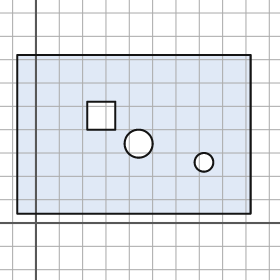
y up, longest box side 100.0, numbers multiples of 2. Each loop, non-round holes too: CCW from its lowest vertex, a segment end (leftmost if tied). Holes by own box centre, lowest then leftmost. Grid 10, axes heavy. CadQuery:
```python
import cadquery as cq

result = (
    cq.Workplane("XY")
    .moveTo(-8.0, 4.0)
    .lineTo(92.0, 4.0)
    .lineTo(92.0, 72.0)
    .lineTo(-8.0, 72.0)
    .close()
    .moveTo(72.0, 26.0)
    .circle(4.0)
    .moveTo(44.0, 34.0)
    .circle(6.0)
    .moveTo(22.0, 40.0)
    .lineTo(34.0, 40.0)
    .lineTo(34.0, 52.0)
    .lineTo(22.0, 52.0)
    .close()
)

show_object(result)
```